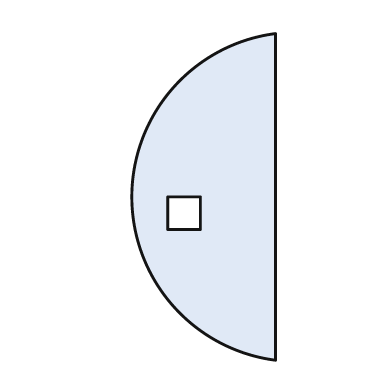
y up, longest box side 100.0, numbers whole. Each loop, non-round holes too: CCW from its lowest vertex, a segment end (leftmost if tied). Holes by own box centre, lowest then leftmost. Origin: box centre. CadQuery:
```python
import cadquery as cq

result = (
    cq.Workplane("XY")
    .moveTo(22.0, -50.0)
    .lineTo(22.0, 50.0)
    .threePointArc((-22.0, 0.0), (22.0, -50.0))
    .close()
    .moveTo(-11.0, -10.0)
    .lineTo(-1.0, -10.0)
    .lineTo(-1.0, 0.0)
    .lineTo(-11.0, 0.0)
    .close()
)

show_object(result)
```